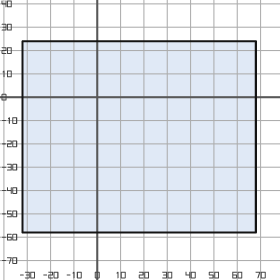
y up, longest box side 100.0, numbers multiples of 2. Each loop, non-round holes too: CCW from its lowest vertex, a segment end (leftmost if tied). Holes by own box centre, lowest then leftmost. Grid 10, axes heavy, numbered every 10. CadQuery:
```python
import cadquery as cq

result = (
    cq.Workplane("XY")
    .moveTo(-32.0, -58.0)
    .lineTo(68.0, -58.0)
    .lineTo(68.0, 24.0)
    .lineTo(-32.0, 24.0)
    .close()
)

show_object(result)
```